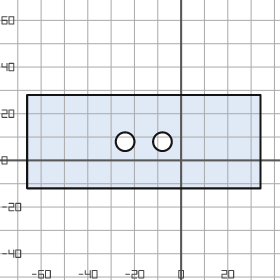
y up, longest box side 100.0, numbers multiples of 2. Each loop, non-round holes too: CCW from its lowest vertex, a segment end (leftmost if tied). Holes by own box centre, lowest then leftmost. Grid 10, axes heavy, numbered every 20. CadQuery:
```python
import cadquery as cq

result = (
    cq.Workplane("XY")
    .moveTo(-66.0, -12.0)
    .lineTo(34.0, -12.0)
    .lineTo(34.0, 28.0)
    .lineTo(-66.0, 28.0)
    .close()
    .moveTo(-24.0, 8.0)
    .circle(4.0)
    .moveTo(-8.0, 8.0)
    .circle(4.0)
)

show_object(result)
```